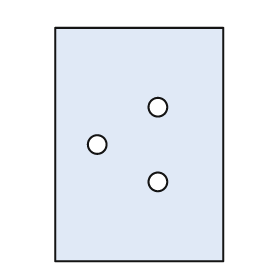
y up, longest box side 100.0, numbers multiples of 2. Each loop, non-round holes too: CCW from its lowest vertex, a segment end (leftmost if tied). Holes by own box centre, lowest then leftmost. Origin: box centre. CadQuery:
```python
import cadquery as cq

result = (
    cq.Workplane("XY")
    .moveTo(-36.0, -50.0)
    .lineTo(36.0, -50.0)
    .lineTo(36.0, 50.0)
    .lineTo(-36.0, 50.0)
    .close()
    .moveTo(8.0, -16.0)
    .circle(4.0)
    .moveTo(-18.0, 0.0)
    .circle(4.0)
    .moveTo(8.0, 16.0)
    .circle(4.0)
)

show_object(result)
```